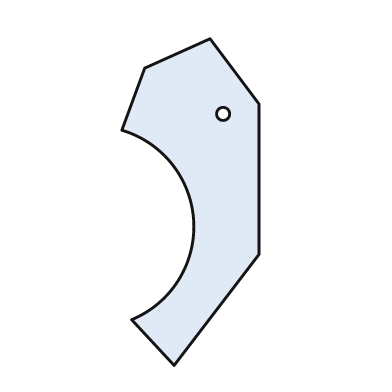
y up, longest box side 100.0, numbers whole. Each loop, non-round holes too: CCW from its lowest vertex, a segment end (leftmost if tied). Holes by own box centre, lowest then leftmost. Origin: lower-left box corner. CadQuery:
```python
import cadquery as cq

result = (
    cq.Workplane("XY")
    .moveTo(16.0, 0.0)
    .lineTo(42.0, 34.0)
    .lineTo(42.0, 80.0)
    .lineTo(27.0, 100.0)
    .lineTo(7.0, 91.0)
    .lineTo(0.0, 72.0)
    .threePointArc((22.0, 44.0), (3.0, 14.0))
    .close()
    .moveTo(31.0, 77.0)
    .circle(2.0)
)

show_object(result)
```